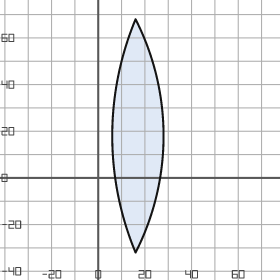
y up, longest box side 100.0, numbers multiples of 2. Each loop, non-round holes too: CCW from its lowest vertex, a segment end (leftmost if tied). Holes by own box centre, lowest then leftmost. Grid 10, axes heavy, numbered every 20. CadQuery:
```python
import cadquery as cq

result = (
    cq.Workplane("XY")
    .moveTo(16.0, -32.0)
    .threePointArc((28.0, 18.0), (16.0, 68.0))
    .threePointArc((6.0, 18.0), (16.0, -32.0))
    .close()
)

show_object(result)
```